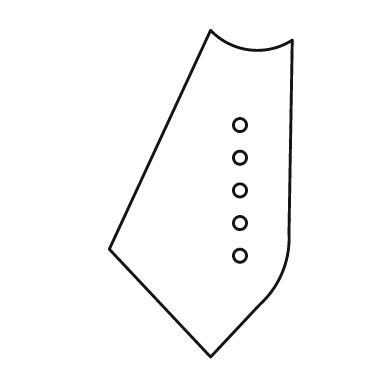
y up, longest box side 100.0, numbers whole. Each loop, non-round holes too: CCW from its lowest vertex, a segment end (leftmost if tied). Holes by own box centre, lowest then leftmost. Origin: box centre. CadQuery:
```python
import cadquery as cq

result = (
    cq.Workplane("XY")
    .moveTo(3.0, -50.0)
    .lineTo(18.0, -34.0)
    .threePointArc((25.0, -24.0), (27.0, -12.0))
    .lineTo(28.0, 47.0)
    .threePointArc((15.0, 44.0), (3.0, 50.0))
    .lineTo(-28.0, -17.0)
    .close()
    .moveTo(12.0, -19.0)
    .circle(2.0)
    .moveTo(12.0, -9.0)
    .circle(2.0)
    .moveTo(12.0, 1.0)
    .circle(2.0)
    .moveTo(12.0, 11.0)
    .circle(2.0)
    .moveTo(12.0, 21.0)
    .circle(2.0)
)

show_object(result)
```